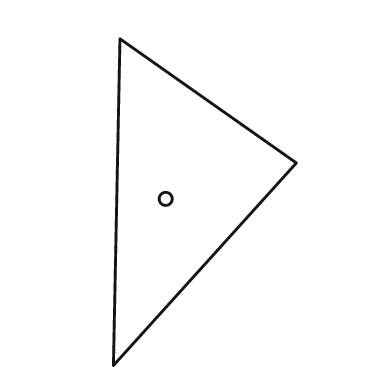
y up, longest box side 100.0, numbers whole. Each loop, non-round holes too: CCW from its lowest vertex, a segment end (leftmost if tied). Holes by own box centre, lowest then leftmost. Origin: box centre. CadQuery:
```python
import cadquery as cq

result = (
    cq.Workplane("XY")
    .moveTo(-28.0, -50.0)
    .lineTo(28.0, 12.0)
    .lineTo(-26.0, 50.0)
    .close()
    .moveTo(-12.0, 1.0)
    .circle(2.0)
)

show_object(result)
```